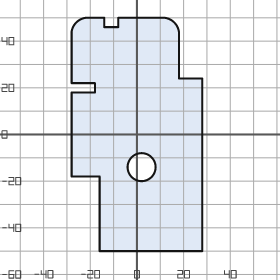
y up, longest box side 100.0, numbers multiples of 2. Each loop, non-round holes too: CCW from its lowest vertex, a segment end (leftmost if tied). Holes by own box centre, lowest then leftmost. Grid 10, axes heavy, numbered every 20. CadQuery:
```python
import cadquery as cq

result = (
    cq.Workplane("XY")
    .moveTo(-16.0, -50.0)
    .lineTo(28.0, -50.0)
    .lineTo(28.0, 24.0)
    .lineTo(18.0, 24.0)
    .lineTo(18.0, 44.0)
    .threePointArc((16.0, 48.0), (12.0, 50.0))
    .lineTo(-8.0, 50.0)
    .lineTo(-8.0, 46.0)
    .lineTo(-14.0, 46.0)
    .lineTo(-14.0, 50.0)
    .lineTo(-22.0, 50.0)
    .threePointArc((-26.0, 48.0), (-28.0, 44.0))
    .lineTo(-28.0, 22.0)
    .lineTo(-18.0, 22.0)
    .lineTo(-18.0, 18.0)
    .lineTo(-28.0, 18.0)
    .lineTo(-28.0, -18.0)
    .lineTo(-16.0, -18.0)
    .close()
    .moveTo(2.0, -14.0)
    .circle(6.0)
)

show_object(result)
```